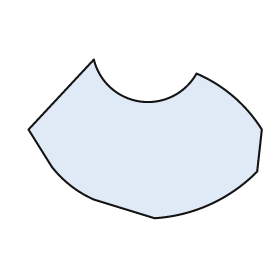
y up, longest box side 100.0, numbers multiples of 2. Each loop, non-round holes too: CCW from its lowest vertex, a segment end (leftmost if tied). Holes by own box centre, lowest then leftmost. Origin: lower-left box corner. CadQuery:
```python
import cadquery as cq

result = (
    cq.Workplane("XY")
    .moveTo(54.0, 0.0)
    .threePointArc((78.0, 6.0), (98.0, 20.0))
    .lineTo(100.0, 38.0)
    .threePointArc((88.0, 52.0), (72.0, 62.0))
    .threePointArc((48.0, 50.0), (28.0, 68.0))
    .lineTo(0.0, 38.0)
    .lineTo(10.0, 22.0)
    .threePointArc((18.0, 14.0), (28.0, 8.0))
    .close()
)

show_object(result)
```